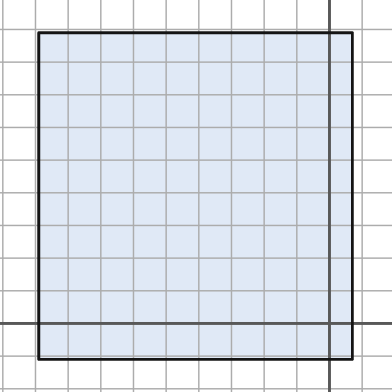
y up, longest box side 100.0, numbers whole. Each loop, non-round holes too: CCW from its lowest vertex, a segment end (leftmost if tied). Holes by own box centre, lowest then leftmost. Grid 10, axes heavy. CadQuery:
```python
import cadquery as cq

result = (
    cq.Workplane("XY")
    .moveTo(-89.0, -11.0)
    .lineTo(7.0, -11.0)
    .lineTo(7.0, 89.0)
    .lineTo(-89.0, 89.0)
    .close()
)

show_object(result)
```